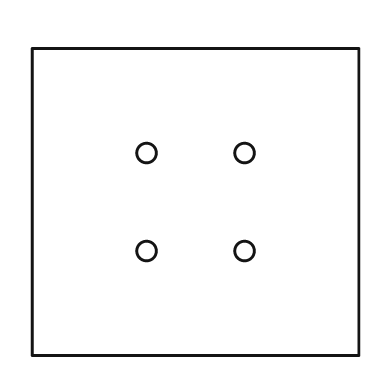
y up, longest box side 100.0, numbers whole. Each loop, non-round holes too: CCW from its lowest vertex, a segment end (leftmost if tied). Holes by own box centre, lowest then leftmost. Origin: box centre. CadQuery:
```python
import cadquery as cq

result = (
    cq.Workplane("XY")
    .moveTo(-50.0, -47.0)
    .lineTo(50.0, -47.0)
    .lineTo(50.0, 47.0)
    .lineTo(-50.0, 47.0)
    .close()
    .moveTo(-15.0, -15.0)
    .circle(3.0)
    .moveTo(15.0, -15.0)
    .circle(3.0)
    .moveTo(-15.0, 15.0)
    .circle(3.0)
    .moveTo(15.0, 15.0)
    .circle(3.0)
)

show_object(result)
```